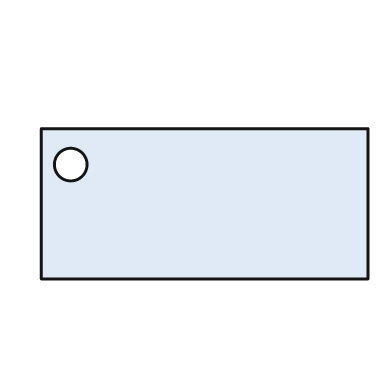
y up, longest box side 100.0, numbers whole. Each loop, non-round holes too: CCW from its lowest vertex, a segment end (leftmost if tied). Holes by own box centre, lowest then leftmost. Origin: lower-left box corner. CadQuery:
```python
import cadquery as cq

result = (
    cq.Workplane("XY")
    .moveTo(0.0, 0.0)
    .lineTo(100.0, 0.0)
    .lineTo(100.0, 46.0)
    .lineTo(0.0, 46.0)
    .close()
    .moveTo(9.0, 35.0)
    .circle(5.0)
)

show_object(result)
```